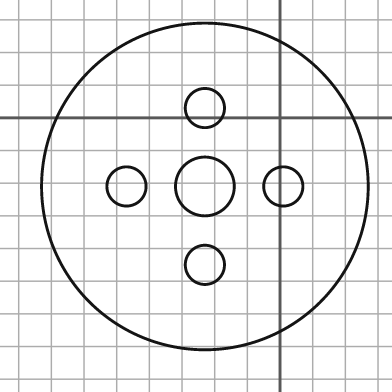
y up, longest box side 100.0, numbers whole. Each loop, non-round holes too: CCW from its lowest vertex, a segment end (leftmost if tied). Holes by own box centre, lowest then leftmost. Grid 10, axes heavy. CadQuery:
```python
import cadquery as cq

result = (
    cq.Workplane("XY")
    .moveTo(-23.0, -21.0)
    .circle(50.0)
    .moveTo(-23.0, -45.0)
    .circle(6.0)
    .moveTo(-47.0, -21.0)
    .circle(6.0)
    .moveTo(-23.0, -21.0)
    .circle(9.0)
    .moveTo(1.0, -21.0)
    .circle(6.0)
    .moveTo(-23.0, 3.0)
    .circle(6.0)
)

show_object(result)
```